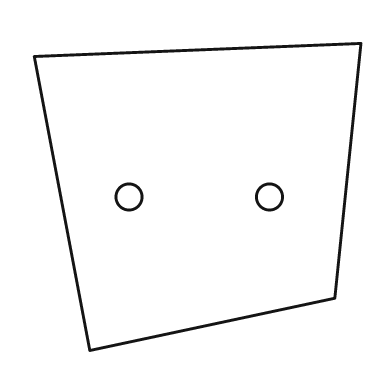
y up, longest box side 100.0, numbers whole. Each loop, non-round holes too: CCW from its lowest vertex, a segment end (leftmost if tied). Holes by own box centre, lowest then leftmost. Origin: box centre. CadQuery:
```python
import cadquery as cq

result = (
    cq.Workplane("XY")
    .moveTo(-33.0, -47.0)
    .lineTo(42.0, -31.0)
    .lineTo(50.0, 47.0)
    .lineTo(-50.0, 43.0)
    .close()
    .moveTo(-21.0, 0.0)
    .circle(4.0)
    .moveTo(22.0, 0.0)
    .circle(4.0)
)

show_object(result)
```